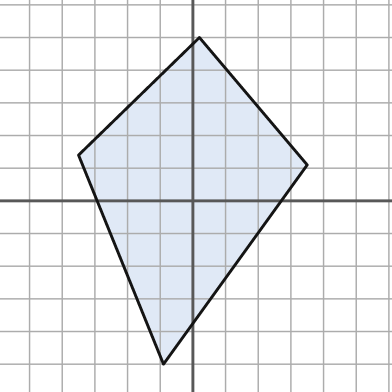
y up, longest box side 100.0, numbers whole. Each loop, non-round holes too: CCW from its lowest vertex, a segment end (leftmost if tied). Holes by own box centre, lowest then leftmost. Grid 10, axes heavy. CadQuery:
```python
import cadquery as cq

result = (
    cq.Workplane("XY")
    .moveTo(-9.0, -50.0)
    .lineTo(35.0, 11.0)
    .lineTo(2.0, 50.0)
    .lineTo(-35.0, 14.0)
    .close()
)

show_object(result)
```